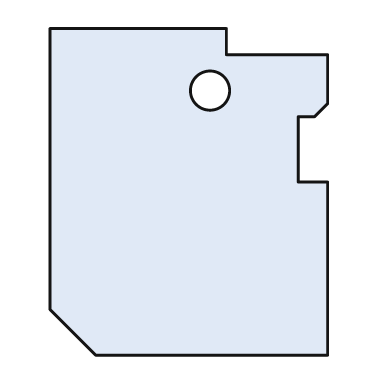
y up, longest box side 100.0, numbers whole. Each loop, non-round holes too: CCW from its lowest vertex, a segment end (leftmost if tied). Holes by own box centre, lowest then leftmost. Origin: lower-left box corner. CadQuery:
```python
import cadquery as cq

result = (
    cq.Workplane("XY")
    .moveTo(14.0, 0.0)
    .lineTo(85.0, 0.0)
    .lineTo(85.0, 53.0)
    .lineTo(76.0, 53.0)
    .lineTo(76.0, 73.0)
    .lineTo(81.0, 73.0)
    .lineTo(85.0, 77.0)
    .lineTo(85.0, 92.0)
    .lineTo(54.0, 92.0)
    .lineTo(54.0, 100.0)
    .lineTo(0.0, 100.0)
    .lineTo(0.0, 14.0)
    .close()
    .moveTo(49.0, 81.0)
    .circle(6.0)
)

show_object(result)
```